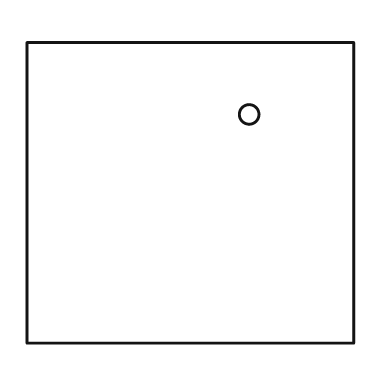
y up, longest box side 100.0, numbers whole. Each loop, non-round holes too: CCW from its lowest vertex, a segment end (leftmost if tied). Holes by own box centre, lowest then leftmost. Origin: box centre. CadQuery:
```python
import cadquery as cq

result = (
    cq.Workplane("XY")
    .moveTo(-50.0, -46.0)
    .lineTo(50.0, -46.0)
    .lineTo(50.0, 46.0)
    .lineTo(-50.0, 46.0)
    .close()
    .moveTo(18.0, 24.0)
    .circle(3.0)
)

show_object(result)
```